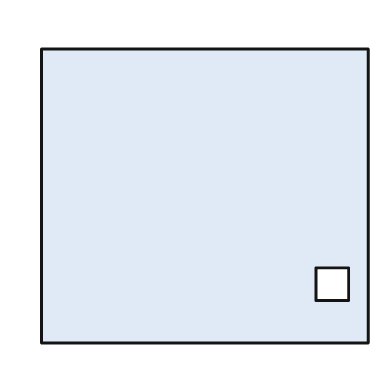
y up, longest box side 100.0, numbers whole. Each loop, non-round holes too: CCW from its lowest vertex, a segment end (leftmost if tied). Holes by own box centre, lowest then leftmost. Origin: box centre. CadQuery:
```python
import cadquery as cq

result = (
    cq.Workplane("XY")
    .moveTo(-50.0, -45.0)
    .lineTo(50.0, -45.0)
    .lineTo(50.0, 45.0)
    .lineTo(-50.0, 45.0)
    .close()
    .moveTo(34.0, -32.0)
    .lineTo(44.0, -32.0)
    .lineTo(44.0, -22.0)
    .lineTo(34.0, -22.0)
    .close()
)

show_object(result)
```